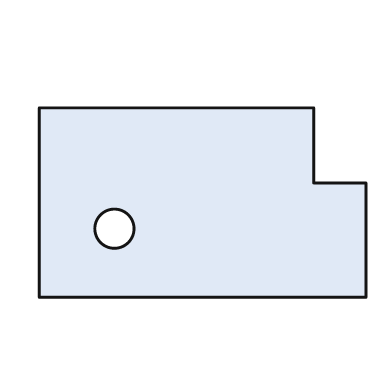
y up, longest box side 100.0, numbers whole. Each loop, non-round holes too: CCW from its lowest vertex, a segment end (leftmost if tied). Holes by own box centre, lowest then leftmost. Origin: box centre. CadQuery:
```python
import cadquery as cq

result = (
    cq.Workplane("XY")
    .moveTo(-50.0, -29.0)
    .lineTo(50.0, -29.0)
    .lineTo(50.0, 6.0)
    .lineTo(34.0, 6.0)
    .lineTo(34.0, 29.0)
    .lineTo(-50.0, 29.0)
    .close()
    .moveTo(-27.0, -8.0)
    .circle(6.0)
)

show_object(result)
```